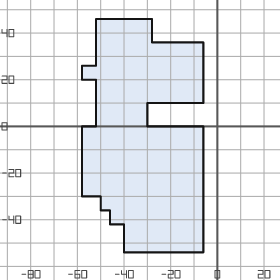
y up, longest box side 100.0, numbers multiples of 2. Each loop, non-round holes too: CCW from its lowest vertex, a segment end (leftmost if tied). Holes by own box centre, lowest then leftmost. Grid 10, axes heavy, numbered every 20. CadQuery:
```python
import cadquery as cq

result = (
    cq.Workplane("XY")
    .moveTo(-40.0, -54.0)
    .lineTo(-6.0, -54.0)
    .lineTo(-6.0, 0.0)
    .lineTo(-30.0, 0.0)
    .lineTo(-30.0, 10.0)
    .lineTo(-6.0, 10.0)
    .lineTo(-6.0, 36.0)
    .lineTo(-28.0, 36.0)
    .lineTo(-28.0, 46.0)
    .lineTo(-52.0, 46.0)
    .lineTo(-52.0, 26.0)
    .lineTo(-58.0, 26.0)
    .lineTo(-58.0, 20.0)
    .lineTo(-52.0, 20.0)
    .lineTo(-52.0, 0.0)
    .lineTo(-58.0, 0.0)
    .lineTo(-58.0, -30.0)
    .lineTo(-50.0, -30.0)
    .lineTo(-50.0, -36.0)
    .lineTo(-46.0, -36.0)
    .lineTo(-46.0, -42.0)
    .lineTo(-40.0, -42.0)
    .close()
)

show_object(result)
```